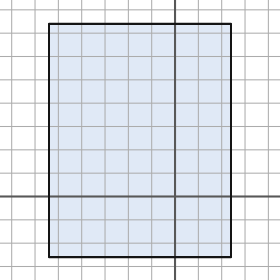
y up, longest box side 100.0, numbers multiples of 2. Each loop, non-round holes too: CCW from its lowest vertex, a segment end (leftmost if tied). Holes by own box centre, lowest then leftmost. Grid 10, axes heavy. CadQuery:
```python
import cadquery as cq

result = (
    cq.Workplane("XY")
    .moveTo(-54.0, -26.0)
    .lineTo(24.0, -26.0)
    .lineTo(24.0, 74.0)
    .lineTo(-54.0, 74.0)
    .close()
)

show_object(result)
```